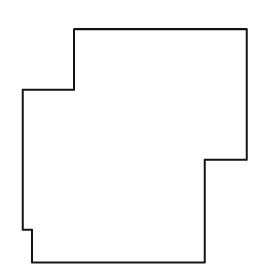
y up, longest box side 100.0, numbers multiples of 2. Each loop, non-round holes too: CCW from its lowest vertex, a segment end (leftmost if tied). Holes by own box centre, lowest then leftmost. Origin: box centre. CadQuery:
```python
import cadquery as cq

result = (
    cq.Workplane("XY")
    .moveTo(-44.0, -50.0)
    .lineTo(30.0, -50.0)
    .lineTo(30.0, -6.0)
    .lineTo(48.0, -6.0)
    .lineTo(48.0, 50.0)
    .lineTo(-26.0, 50.0)
    .lineTo(-26.0, 24.0)
    .lineTo(-48.0, 24.0)
    .lineTo(-48.0, -36.0)
    .lineTo(-44.0, -36.0)
    .close()
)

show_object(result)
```